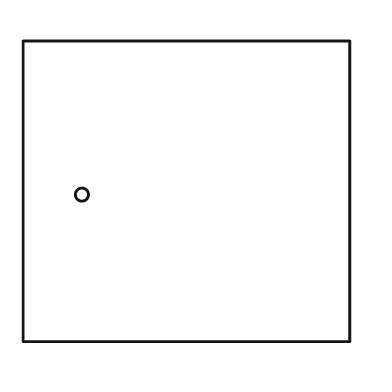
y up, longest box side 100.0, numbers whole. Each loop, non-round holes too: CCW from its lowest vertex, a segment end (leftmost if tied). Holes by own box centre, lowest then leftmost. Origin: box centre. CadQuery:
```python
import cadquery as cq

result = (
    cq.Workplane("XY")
    .moveTo(-50.0, -46.0)
    .lineTo(50.0, -46.0)
    .lineTo(50.0, 46.0)
    .lineTo(-50.0, 46.0)
    .close()
    .moveTo(-32.0, -1.0)
    .circle(2.0)
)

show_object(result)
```